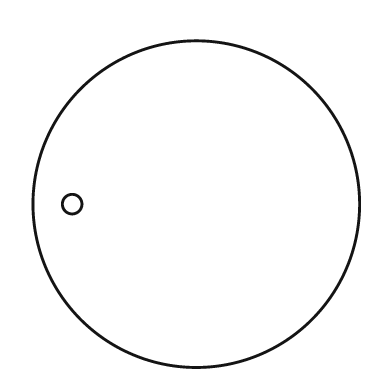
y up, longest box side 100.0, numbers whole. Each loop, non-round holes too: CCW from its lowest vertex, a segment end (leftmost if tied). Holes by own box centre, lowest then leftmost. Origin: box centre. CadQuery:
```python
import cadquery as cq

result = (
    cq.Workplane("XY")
    .moveTo(0.0, 0.0)
    .circle(50.0)
    .moveTo(-38.0, 0.0)
    .circle(3.0)
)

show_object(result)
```